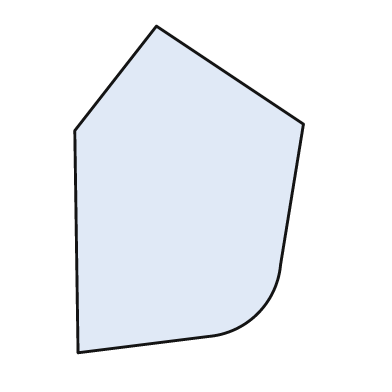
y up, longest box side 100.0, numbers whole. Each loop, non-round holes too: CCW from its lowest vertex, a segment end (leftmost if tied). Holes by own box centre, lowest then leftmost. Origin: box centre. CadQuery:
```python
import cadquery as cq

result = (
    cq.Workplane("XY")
    .moveTo(-34.0, -50.0)
    .lineTo(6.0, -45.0)
    .threePointArc((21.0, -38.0), (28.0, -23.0))
    .lineTo(35.0, 20.0)
    .lineTo(-10.0, 50.0)
    .lineTo(-35.0, 18.0)
    .close()
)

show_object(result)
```